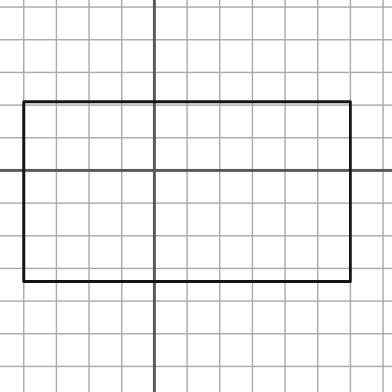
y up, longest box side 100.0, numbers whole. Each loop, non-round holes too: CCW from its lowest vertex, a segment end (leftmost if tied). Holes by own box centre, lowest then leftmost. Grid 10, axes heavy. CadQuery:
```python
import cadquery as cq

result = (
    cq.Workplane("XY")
    .moveTo(-40.0, -34.0)
    .lineTo(60.0, -34.0)
    .lineTo(60.0, 21.0)
    .lineTo(-40.0, 21.0)
    .close()
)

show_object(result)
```